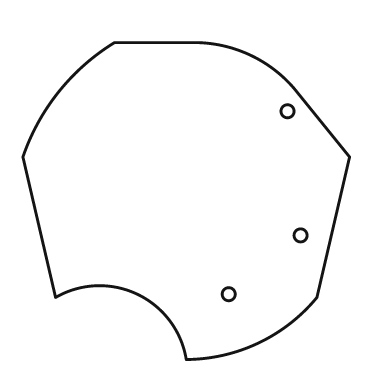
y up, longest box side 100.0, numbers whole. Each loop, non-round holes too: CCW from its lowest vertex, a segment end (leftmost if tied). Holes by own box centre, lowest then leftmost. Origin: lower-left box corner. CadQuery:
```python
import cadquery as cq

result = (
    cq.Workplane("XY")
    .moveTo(50.0, 0.0)
    .threePointArc((72.0, 5.0), (90.0, 19.0))
    .lineTo(100.0, 62.0)
    .lineTo(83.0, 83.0)
    .threePointArc((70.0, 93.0), (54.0, 97.0))
    .lineTo(28.0, 97.0)
    .threePointArc((11.0, 82.0), (0.0, 62.0))
    .lineTo(10.0, 19.0)
    .threePointArc((35.0, 20.0), (50.0, 0.0))
    .close()
    .moveTo(63.0, 20.0)
    .circle(2.0)
    .moveTo(85.0, 38.0)
    .circle(2.0)
    .moveTo(81.0, 76.0)
    .circle(2.0)
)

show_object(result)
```